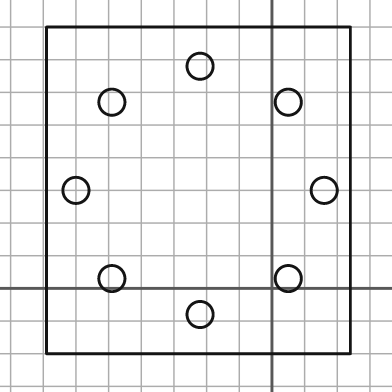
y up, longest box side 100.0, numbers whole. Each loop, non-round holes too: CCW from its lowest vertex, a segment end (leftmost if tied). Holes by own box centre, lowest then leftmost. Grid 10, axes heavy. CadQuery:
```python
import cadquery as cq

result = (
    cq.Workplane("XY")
    .moveTo(-69.0, -20.0)
    .lineTo(24.0, -20.0)
    .lineTo(24.0, 80.0)
    .lineTo(-69.0, 80.0)
    .close()
    .moveTo(-22.0, -8.0)
    .circle(4.0)
    .moveTo(-49.0, 3.0)
    .circle(4.0)
    .moveTo(5.0, 3.0)
    .circle(4.0)
    .moveTo(-60.0, 30.0)
    .circle(4.0)
    .moveTo(16.0, 30.0)
    .circle(4.0)
    .moveTo(-49.0, 57.0)
    .circle(4.0)
    .moveTo(5.0, 57.0)
    .circle(4.0)
    .moveTo(-22.0, 68.0)
    .circle(4.0)
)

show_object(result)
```